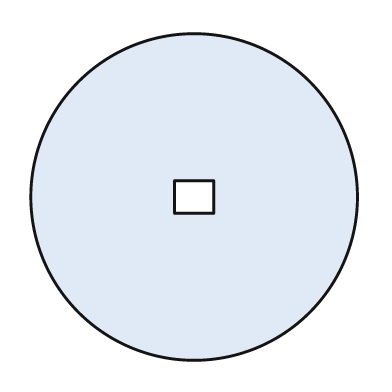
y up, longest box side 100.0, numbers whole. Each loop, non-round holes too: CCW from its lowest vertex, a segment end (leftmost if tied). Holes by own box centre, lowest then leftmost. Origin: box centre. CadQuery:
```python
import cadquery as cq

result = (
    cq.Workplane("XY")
    .moveTo(0.0, 0.0)
    .circle(50.0)
    .moveTo(-6.0, -5.0)
    .lineTo(6.0, -5.0)
    .lineTo(6.0, 5.0)
    .lineTo(-6.0, 5.0)
    .close()
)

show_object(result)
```